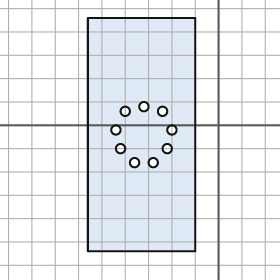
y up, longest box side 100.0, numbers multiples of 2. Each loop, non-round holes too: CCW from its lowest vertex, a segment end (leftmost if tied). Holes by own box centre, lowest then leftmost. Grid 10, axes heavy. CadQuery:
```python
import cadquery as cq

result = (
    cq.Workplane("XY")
    .moveTo(-56.0, -54.0)
    .lineTo(-10.0, -54.0)
    .lineTo(-10.0, 46.0)
    .lineTo(-56.0, 46.0)
    .close()
    .moveTo(-36.0, -16.0)
    .circle(2.0)
    .moveTo(-28.0, -16.0)
    .circle(2.0)
    .moveTo(-42.0, -10.0)
    .circle(2.0)
    .moveTo(-22.0, -10.0)
    .circle(2.0)
    .moveTo(-44.0, -2.0)
    .circle(2.0)
    .moveTo(-20.0, -2.0)
    .circle(2.0)
    .moveTo(-40.0, 6.0)
    .circle(2.0)
    .moveTo(-24.0, 6.0)
    .circle(2.0)
    .moveTo(-32.0, 8.0)
    .circle(2.0)
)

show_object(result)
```